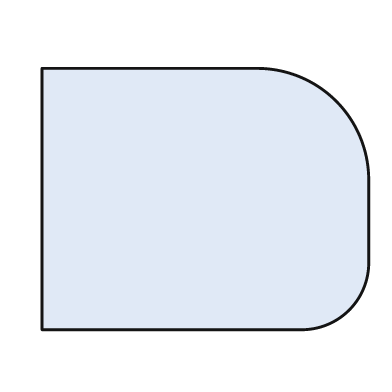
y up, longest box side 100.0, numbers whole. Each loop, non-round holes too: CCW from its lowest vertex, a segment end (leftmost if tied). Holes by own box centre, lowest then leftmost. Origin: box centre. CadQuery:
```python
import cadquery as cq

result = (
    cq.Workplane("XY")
    .moveTo(-50.0, -40.0)
    .lineTo(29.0, -40.0)
    .threePointArc((44.0, -34.0), (50.0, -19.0))
    .lineTo(50.0, 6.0)
    .threePointArc((40.0, 30.0), (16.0, 40.0))
    .lineTo(-50.0, 40.0)
    .close()
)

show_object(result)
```